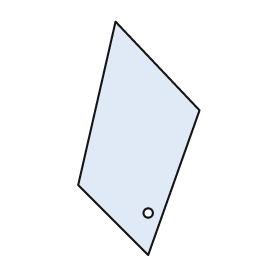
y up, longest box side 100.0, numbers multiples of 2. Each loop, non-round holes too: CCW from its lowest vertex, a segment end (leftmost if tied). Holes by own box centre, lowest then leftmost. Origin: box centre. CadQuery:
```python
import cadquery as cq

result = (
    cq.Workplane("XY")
    .moveTo(4.0, -50.0)
    .lineTo(26.0, 12.0)
    .lineTo(-10.0, 50.0)
    .lineTo(-26.0, -20.0)
    .close()
    .moveTo(4.0, -32.0)
    .circle(2.0)
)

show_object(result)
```